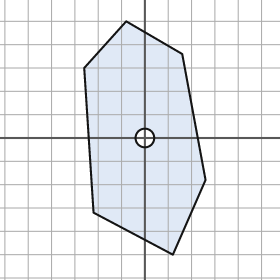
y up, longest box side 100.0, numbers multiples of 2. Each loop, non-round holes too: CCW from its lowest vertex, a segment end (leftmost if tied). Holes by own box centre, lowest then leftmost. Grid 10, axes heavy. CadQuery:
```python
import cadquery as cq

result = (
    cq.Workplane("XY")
    .moveTo(12.0, -50.0)
    .lineTo(26.0, -18.0)
    .lineTo(16.0, 36.0)
    .lineTo(-8.0, 50.0)
    .lineTo(-26.0, 30.0)
    .lineTo(-22.0, -32.0)
    .close()
    .moveTo(0.0, 0.0)
    .circle(4.0)
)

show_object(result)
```